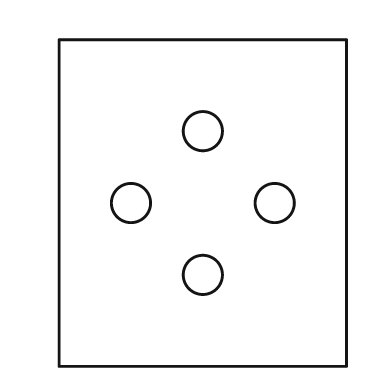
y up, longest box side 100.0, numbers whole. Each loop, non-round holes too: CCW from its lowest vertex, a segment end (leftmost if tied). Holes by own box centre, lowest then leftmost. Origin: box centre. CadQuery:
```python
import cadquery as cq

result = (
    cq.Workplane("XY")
    .moveTo(-44.0, -50.0)
    .lineTo(44.0, -50.0)
    .lineTo(44.0, 50.0)
    .lineTo(-44.0, 50.0)
    .close()
    .moveTo(0.0, -22.0)
    .circle(6.0)
    .moveTo(-22.0, 0.0)
    .circle(6.0)
    .moveTo(22.0, 0.0)
    .circle(6.0)
    .moveTo(0.0, 22.0)
    .circle(6.0)
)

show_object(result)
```